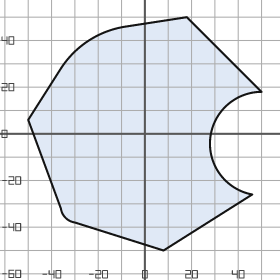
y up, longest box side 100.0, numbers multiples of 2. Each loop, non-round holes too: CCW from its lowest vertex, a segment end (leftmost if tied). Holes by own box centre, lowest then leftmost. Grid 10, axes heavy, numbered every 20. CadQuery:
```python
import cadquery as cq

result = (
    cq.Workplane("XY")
    .moveTo(8.0, -50.0)
    .lineTo(46.0, -26.0)
    .threePointArc((28.0, -2.0), (50.0, 18.0))
    .lineTo(18.0, 50.0)
    .lineTo(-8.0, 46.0)
    .threePointArc((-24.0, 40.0), (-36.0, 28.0))
    .lineTo(-50.0, 6.0)
    .lineTo(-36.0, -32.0)
    .threePointArc((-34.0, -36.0), (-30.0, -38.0))
    .close()
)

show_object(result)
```